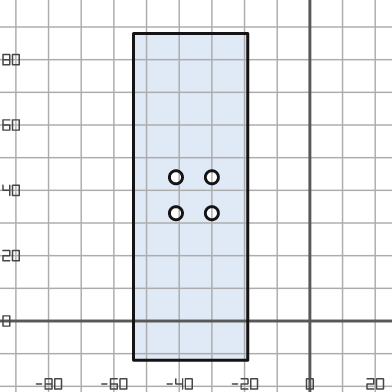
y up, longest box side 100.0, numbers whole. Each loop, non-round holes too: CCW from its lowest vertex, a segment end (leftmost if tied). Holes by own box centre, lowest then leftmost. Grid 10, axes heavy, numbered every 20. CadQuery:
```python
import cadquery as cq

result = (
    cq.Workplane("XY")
    .moveTo(-54.0, -12.0)
    .lineTo(-19.0, -12.0)
    .lineTo(-19.0, 88.0)
    .lineTo(-54.0, 88.0)
    .close()
    .moveTo(-41.0, 33.0)
    .circle(2.0)
    .moveTo(-30.0, 33.0)
    .circle(2.0)
    .moveTo(-41.0, 44.0)
    .circle(2.0)
    .moveTo(-30.0, 44.0)
    .circle(2.0)
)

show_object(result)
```